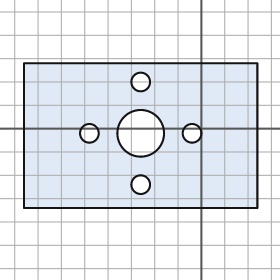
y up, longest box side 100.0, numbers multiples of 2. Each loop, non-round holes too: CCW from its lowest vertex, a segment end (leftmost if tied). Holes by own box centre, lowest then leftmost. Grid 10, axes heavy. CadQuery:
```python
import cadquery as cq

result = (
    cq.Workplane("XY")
    .moveTo(-76.0, -34.0)
    .lineTo(24.0, -34.0)
    .lineTo(24.0, 28.0)
    .lineTo(-76.0, 28.0)
    .close()
    .moveTo(-26.0, -24.0)
    .circle(4.0)
    .moveTo(-48.0, -2.0)
    .circle(4.0)
    .moveTo(-26.0, -2.0)
    .circle(10.0)
    .moveTo(-4.0, -2.0)
    .circle(4.0)
    .moveTo(-26.0, 20.0)
    .circle(4.0)
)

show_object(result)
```